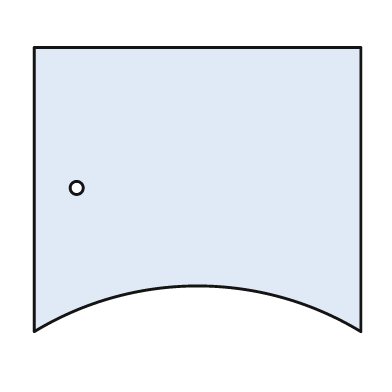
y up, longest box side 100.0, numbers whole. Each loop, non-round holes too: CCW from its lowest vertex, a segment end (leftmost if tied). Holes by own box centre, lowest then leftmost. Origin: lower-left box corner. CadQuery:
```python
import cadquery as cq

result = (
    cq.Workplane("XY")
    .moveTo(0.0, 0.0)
    .threePointArc((50.0, 14.0), (100.0, 0.0))
    .lineTo(100.0, 87.0)
    .lineTo(0.0, 87.0)
    .close()
    .moveTo(13.0, 44.0)
    .circle(2.0)
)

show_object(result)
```